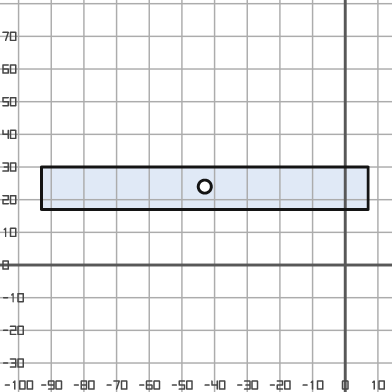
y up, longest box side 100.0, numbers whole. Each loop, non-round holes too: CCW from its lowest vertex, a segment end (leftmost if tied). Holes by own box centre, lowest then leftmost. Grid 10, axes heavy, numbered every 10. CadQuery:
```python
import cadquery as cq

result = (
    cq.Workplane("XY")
    .moveTo(-93.0, 17.0)
    .lineTo(7.0, 17.0)
    .lineTo(7.0, 30.0)
    .lineTo(-93.0, 30.0)
    .close()
    .moveTo(-43.0, 24.0)
    .circle(2.0)
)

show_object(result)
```